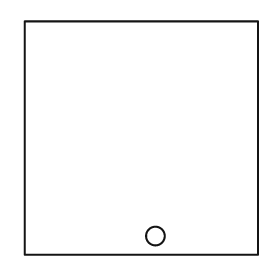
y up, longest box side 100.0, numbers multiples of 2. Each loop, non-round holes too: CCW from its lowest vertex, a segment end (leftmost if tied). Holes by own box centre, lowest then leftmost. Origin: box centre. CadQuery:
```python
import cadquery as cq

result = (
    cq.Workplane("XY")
    .moveTo(-50.0, -50.0)
    .lineTo(50.0, -50.0)
    .lineTo(50.0, 50.0)
    .lineTo(-50.0, 50.0)
    .close()
    .moveTo(6.0, -42.0)
    .circle(4.0)
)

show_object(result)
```